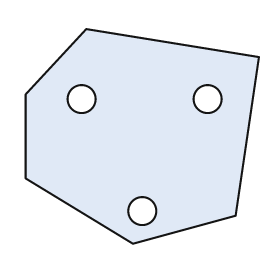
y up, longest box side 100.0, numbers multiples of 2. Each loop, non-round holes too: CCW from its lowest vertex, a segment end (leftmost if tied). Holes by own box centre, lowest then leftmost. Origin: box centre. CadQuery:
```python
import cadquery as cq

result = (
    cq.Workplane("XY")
    .moveTo(-4.0, -46.0)
    .lineTo(40.0, -34.0)
    .lineTo(50.0, 34.0)
    .lineTo(-24.0, 46.0)
    .lineTo(-50.0, 18.0)
    .lineTo(-50.0, -18.0)
    .close()
    .moveTo(0.0, -32.0)
    .circle(6.0)
    .moveTo(-26.0, 16.0)
    .circle(6.0)
    .moveTo(28.0, 16.0)
    .circle(6.0)
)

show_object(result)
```